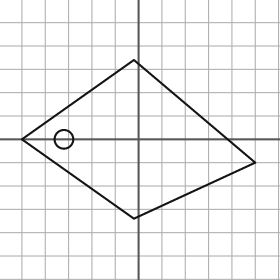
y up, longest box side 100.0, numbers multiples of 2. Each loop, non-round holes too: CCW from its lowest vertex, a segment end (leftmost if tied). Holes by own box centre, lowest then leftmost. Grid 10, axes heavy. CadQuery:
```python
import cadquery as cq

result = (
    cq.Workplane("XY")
    .moveTo(-2.0, -34.0)
    .lineTo(50.0, -10.0)
    .lineTo(-2.0, 34.0)
    .lineTo(-50.0, 0.0)
    .close()
    .moveTo(-32.0, 0.0)
    .circle(4.0)
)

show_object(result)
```